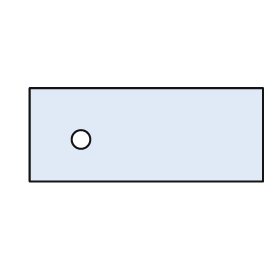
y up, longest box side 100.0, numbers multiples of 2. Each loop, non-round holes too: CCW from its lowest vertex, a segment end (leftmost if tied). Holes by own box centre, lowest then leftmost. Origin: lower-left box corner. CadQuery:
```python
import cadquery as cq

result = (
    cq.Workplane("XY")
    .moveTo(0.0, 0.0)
    .lineTo(100.0, 0.0)
    .lineTo(100.0, 40.0)
    .lineTo(0.0, 40.0)
    .close()
    .moveTo(22.0, 18.0)
    .circle(4.0)
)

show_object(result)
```